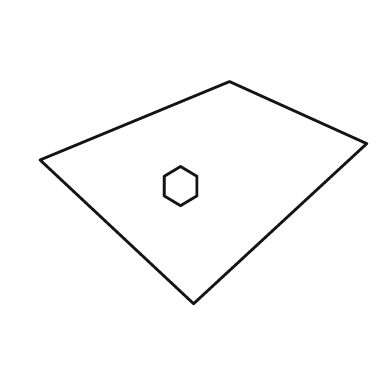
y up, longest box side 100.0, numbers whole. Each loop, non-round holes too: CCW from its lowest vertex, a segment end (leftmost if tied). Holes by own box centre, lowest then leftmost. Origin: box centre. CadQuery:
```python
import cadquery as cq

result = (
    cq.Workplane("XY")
    .moveTo(-3.0, -34.0)
    .lineTo(50.0, 15.0)
    .lineTo(8.0, 34.0)
    .lineTo(-50.0, 10.0)
    .close()
    .moveTo(-7.0, -4.0)
    .lineTo(-2.0, -1.0)
    .lineTo(-2.0, 5.0)
    .lineTo(-7.0, 8.0)
    .lineTo(-12.0, 5.0)
    .lineTo(-12.0, -1.0)
    .close()
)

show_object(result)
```